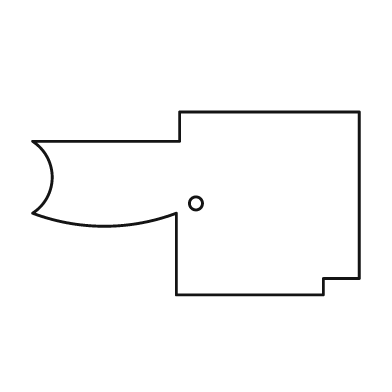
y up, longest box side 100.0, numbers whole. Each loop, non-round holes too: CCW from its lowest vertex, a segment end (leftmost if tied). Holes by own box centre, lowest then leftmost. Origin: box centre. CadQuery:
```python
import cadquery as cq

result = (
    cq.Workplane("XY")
    .moveTo(-6.0, -28.0)
    .lineTo(39.0, -28.0)
    .lineTo(39.0, -23.0)
    .lineTo(50.0, -23.0)
    .lineTo(50.0, 28.0)
    .lineTo(-5.0, 28.0)
    .lineTo(-5.0, 19.0)
    .lineTo(-50.0, 19.0)
    .threePointArc((-44.0, 8.0), (-50.0, -3.0))
    .threePointArc((-28.0, -7.0), (-6.0, -3.0))
    .close()
    .moveTo(0.0, 0.0)
    .circle(2.0)
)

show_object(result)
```